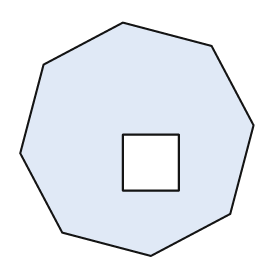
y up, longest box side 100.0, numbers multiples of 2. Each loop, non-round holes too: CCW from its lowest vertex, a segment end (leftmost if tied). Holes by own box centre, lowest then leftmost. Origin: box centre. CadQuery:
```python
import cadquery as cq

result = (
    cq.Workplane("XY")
    .moveTo(6.0, -50.0)
    .lineTo(40.0, -32.0)
    .lineTo(50.0, 6.0)
    .lineTo(32.0, 40.0)
    .lineTo(-6.0, 50.0)
    .lineTo(-40.0, 32.0)
    .lineTo(-50.0, -6.0)
    .lineTo(-32.0, -40.0)
    .close()
    .moveTo(-6.0, -22.0)
    .lineTo(18.0, -22.0)
    .lineTo(18.0, 2.0)
    .lineTo(-6.0, 2.0)
    .close()
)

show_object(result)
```